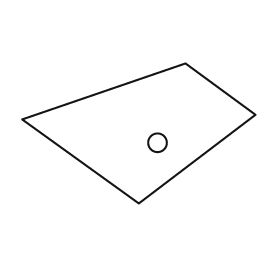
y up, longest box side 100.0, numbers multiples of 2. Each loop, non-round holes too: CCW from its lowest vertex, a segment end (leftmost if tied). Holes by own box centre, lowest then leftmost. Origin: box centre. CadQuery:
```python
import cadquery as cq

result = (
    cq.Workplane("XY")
    .moveTo(0.0, -30.0)
    .lineTo(50.0, 8.0)
    .lineTo(20.0, 30.0)
    .lineTo(-50.0, 6.0)
    .close()
    .moveTo(8.0, -4.0)
    .circle(4.0)
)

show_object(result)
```